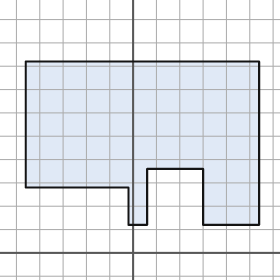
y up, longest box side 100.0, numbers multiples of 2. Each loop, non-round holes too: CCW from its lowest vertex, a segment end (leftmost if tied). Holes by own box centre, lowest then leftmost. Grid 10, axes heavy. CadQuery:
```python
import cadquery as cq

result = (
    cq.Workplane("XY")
    .moveTo(-2.0, 12.0)
    .lineTo(6.0, 12.0)
    .lineTo(6.0, 36.0)
    .lineTo(30.0, 36.0)
    .lineTo(30.0, 12.0)
    .lineTo(54.0, 12.0)
    .lineTo(54.0, 82.0)
    .lineTo(-46.0, 82.0)
    .lineTo(-46.0, 28.0)
    .lineTo(-2.0, 28.0)
    .close()
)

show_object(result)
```